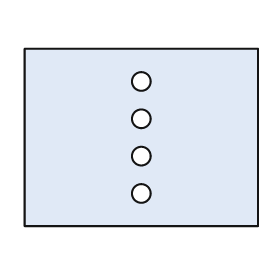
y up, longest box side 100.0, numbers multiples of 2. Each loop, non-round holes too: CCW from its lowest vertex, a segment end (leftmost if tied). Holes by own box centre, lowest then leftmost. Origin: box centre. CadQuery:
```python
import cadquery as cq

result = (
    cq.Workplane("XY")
    .moveTo(-50.0, -38.0)
    .lineTo(50.0, -38.0)
    .lineTo(50.0, 38.0)
    .lineTo(-50.0, 38.0)
    .close()
    .moveTo(0.0, -24.0)
    .circle(4.0)
    .moveTo(0.0, -8.0)
    .circle(4.0)
    .moveTo(0.0, 8.0)
    .circle(4.0)
    .moveTo(0.0, 24.0)
    .circle(4.0)
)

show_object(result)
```